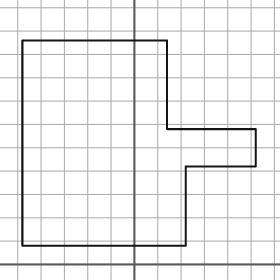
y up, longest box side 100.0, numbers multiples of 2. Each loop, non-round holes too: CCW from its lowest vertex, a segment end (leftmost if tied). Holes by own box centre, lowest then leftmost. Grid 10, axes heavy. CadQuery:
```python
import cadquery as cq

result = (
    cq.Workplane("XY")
    .moveTo(-48.0, 8.0)
    .lineTo(22.0, 8.0)
    .lineTo(22.0, 42.0)
    .lineTo(52.0, 42.0)
    .lineTo(52.0, 58.0)
    .lineTo(14.0, 58.0)
    .lineTo(14.0, 96.0)
    .lineTo(-48.0, 96.0)
    .close()
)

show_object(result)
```